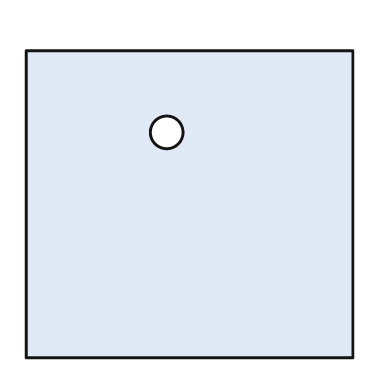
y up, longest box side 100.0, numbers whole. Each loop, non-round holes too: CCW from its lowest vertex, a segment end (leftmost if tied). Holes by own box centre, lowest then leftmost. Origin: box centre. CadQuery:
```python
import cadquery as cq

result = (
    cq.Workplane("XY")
    .moveTo(-50.0, -47.0)
    .lineTo(50.0, -47.0)
    .lineTo(50.0, 47.0)
    .lineTo(-50.0, 47.0)
    .close()
    .moveTo(-7.0, 22.0)
    .circle(5.0)
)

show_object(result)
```